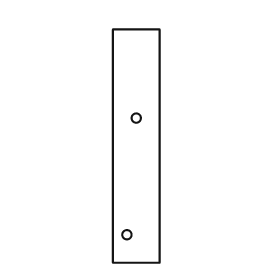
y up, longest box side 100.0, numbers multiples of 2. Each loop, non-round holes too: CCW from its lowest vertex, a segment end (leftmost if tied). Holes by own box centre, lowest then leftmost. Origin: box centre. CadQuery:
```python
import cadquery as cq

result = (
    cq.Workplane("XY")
    .moveTo(-10.0, -50.0)
    .lineTo(10.0, -50.0)
    .lineTo(10.0, 50.0)
    .lineTo(-10.0, 50.0)
    .close()
    .moveTo(-4.0, -38.0)
    .circle(2.0)
    .moveTo(0.0, 12.0)
    .circle(2.0)
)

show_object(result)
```